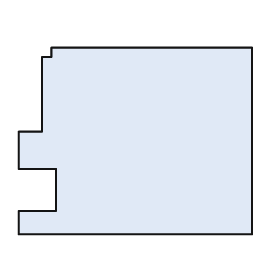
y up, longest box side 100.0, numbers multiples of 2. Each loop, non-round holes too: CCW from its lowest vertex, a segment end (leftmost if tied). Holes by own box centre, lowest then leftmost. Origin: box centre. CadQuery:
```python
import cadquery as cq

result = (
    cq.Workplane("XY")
    .moveTo(-50.0, -40.0)
    .lineTo(50.0, -40.0)
    .lineTo(50.0, 40.0)
    .lineTo(-36.0, 40.0)
    .lineTo(-36.0, 36.0)
    .lineTo(-40.0, 36.0)
    .lineTo(-40.0, 4.0)
    .lineTo(-50.0, 4.0)
    .lineTo(-50.0, -12.0)
    .lineTo(-34.0, -12.0)
    .lineTo(-34.0, -30.0)
    .lineTo(-50.0, -30.0)
    .close()
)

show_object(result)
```